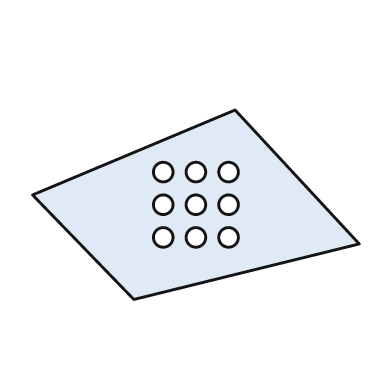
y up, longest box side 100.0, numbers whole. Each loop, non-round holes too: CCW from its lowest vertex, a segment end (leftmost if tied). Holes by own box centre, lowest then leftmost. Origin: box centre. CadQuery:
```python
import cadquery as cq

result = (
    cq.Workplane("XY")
    .moveTo(-19.0, -29.0)
    .lineTo(50.0, -12.0)
    .lineTo(12.0, 29.0)
    .lineTo(-50.0, 3.0)
    .close()
    .moveTo(-10.0, -10.0)
    .circle(3.0)
    .moveTo(0.0, -10.0)
    .circle(3.0)
    .moveTo(10.0, -10.0)
    .circle(3.0)
    .moveTo(-10.0, 0.0)
    .circle(3.0)
    .moveTo(0.0, 0.0)
    .circle(3.0)
    .moveTo(10.0, 0.0)
    .circle(3.0)
    .moveTo(-10.0, 10.0)
    .circle(3.0)
    .moveTo(0.0, 10.0)
    .circle(3.0)
    .moveTo(10.0, 10.0)
    .circle(3.0)
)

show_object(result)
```